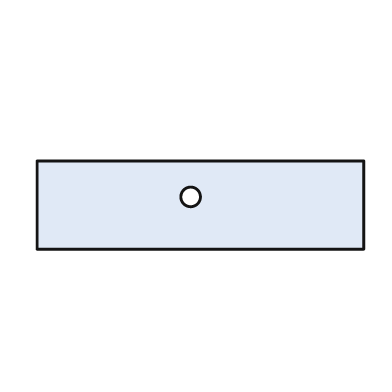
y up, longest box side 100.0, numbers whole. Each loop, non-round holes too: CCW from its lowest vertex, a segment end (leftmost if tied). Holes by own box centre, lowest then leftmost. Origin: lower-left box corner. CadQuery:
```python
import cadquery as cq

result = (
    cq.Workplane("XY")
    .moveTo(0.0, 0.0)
    .lineTo(100.0, 0.0)
    .lineTo(100.0, 27.0)
    .lineTo(0.0, 27.0)
    .close()
    .moveTo(47.0, 16.0)
    .circle(3.0)
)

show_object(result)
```